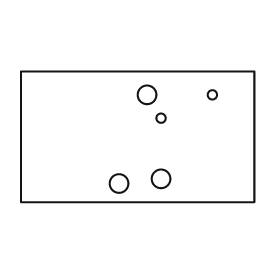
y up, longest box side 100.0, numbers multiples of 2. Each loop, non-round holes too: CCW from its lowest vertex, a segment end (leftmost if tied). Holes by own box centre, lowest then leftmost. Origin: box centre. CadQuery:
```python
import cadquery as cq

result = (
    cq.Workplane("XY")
    .moveTo(-50.0, -28.0)
    .lineTo(50.0, -28.0)
    .lineTo(50.0, 28.0)
    .lineTo(-50.0, 28.0)
    .close()
    .moveTo(-8.0, -20.0)
    .circle(4.0)
    .moveTo(10.0, -18.0)
    .circle(4.0)
    .moveTo(10.0, 8.0)
    .circle(2.0)
    .moveTo(4.0, 18.0)
    .circle(4.0)
    .moveTo(32.0, 18.0)
    .circle(2.0)
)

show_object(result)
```